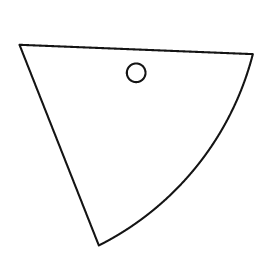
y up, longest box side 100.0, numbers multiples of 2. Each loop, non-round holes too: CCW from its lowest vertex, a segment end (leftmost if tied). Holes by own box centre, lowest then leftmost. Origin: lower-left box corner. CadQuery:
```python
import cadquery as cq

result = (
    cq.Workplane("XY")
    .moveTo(34.0, 0.0)
    .threePointArc((76.0, 34.0), (100.0, 82.0))
    .lineTo(0.0, 86.0)
    .close()
    .moveTo(50.0, 74.0)
    .circle(4.0)
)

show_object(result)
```